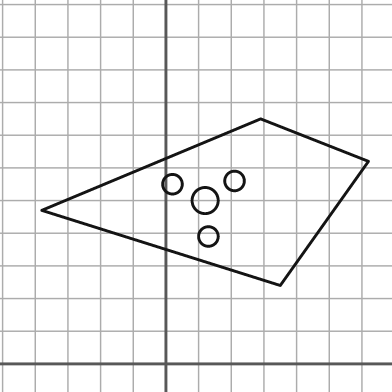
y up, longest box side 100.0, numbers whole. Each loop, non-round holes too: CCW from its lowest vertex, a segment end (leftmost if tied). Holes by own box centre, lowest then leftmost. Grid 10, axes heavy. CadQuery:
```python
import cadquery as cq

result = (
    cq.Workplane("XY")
    .moveTo(35.0, 24.0)
    .lineTo(62.0, 62.0)
    .lineTo(29.0, 75.0)
    .lineTo(-38.0, 47.0)
    .close()
    .moveTo(13.0, 39.0)
    .circle(3.0)
    .moveTo(12.0, 50.0)
    .circle(4.0)
    .moveTo(2.0, 55.0)
    .circle(3.0)
    .moveTo(21.0, 56.0)
    .circle(3.0)
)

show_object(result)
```